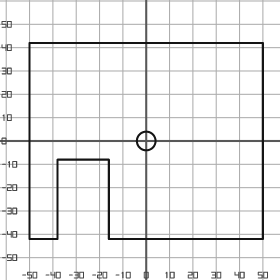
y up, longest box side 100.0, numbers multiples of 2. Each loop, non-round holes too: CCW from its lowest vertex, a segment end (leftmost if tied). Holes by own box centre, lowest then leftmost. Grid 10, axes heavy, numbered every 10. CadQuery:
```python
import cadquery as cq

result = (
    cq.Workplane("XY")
    .moveTo(-50.0, -42.0)
    .lineTo(-38.0, -42.0)
    .lineTo(-38.0, -8.0)
    .lineTo(-16.0, -8.0)
    .lineTo(-16.0, -42.0)
    .lineTo(50.0, -42.0)
    .lineTo(50.0, 42.0)
    .lineTo(-50.0, 42.0)
    .close()
    .moveTo(0.0, 0.0)
    .circle(4.0)
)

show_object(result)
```